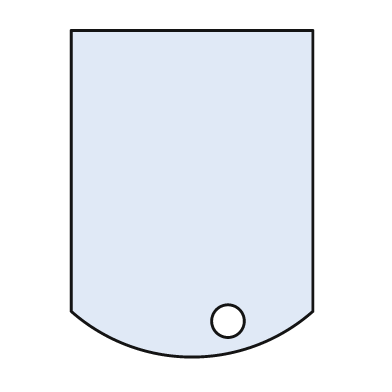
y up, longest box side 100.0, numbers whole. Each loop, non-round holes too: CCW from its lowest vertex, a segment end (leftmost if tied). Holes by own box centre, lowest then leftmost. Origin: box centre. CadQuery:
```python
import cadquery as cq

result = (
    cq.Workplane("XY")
    .moveTo(-37.0, -36.0)
    .threePointArc((0.0, -50.0), (37.0, -36.0))
    .lineTo(37.0, 50.0)
    .lineTo(-37.0, 50.0)
    .close()
    .moveTo(11.0, -39.0)
    .circle(5.0)
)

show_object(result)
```